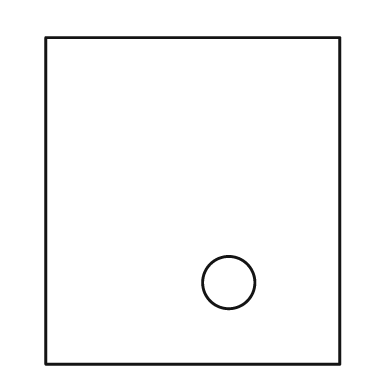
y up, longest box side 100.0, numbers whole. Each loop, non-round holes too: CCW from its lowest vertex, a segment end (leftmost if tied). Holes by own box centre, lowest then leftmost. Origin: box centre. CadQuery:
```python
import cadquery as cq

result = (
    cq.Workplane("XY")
    .moveTo(-45.0, -50.0)
    .lineTo(45.0, -50.0)
    .lineTo(45.0, 50.0)
    .lineTo(-45.0, 50.0)
    .close()
    .moveTo(11.0, -25.0)
    .circle(8.0)
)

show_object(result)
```